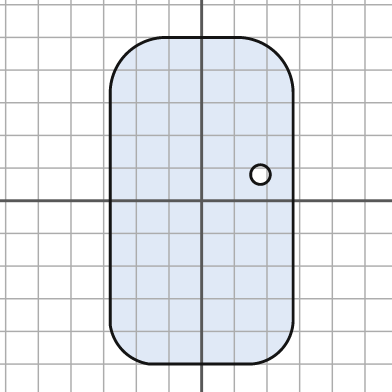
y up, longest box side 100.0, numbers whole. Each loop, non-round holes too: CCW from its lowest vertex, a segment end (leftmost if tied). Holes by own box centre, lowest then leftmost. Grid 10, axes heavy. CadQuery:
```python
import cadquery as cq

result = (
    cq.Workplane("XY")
    .moveTo(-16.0, -50.0)
    .lineTo(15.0, -50.0)
    .threePointArc((24.0, -46.0), (28.0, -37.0))
    .lineTo(28.0, 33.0)
    .threePointArc((23.0, 45.0), (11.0, 50.0))
    .lineTo(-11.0, 50.0)
    .threePointArc((-23.0, 45.0), (-28.0, 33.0))
    .lineTo(-28.0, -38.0)
    .threePointArc((-24.0, -46.0), (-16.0, -50.0))
    .close()
    .moveTo(18.0, 8.0)
    .circle(3.0)
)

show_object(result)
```